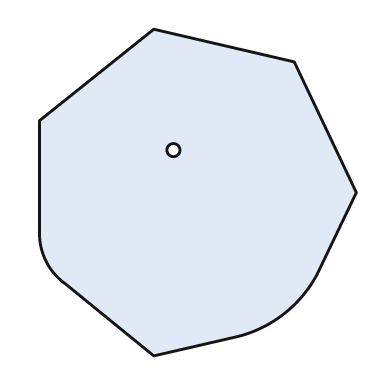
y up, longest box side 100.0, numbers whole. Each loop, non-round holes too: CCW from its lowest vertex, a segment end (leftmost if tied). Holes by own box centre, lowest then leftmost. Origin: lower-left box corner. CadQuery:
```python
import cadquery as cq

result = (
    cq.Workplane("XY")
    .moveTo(35.0, 0.0)
    .lineTo(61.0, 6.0)
    .threePointArc((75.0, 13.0), (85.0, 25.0))
    .lineTo(97.0, 50.0)
    .lineTo(78.0, 90.0)
    .lineTo(35.0, 100.0)
    .lineTo(0.0, 72.0)
    .lineTo(0.0, 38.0)
    .threePointArc((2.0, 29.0), (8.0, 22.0))
    .close()
    .moveTo(41.0, 63.0)
    .circle(2.0)
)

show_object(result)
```